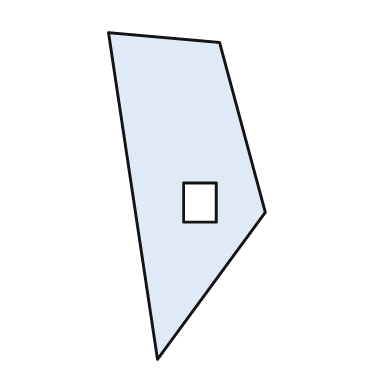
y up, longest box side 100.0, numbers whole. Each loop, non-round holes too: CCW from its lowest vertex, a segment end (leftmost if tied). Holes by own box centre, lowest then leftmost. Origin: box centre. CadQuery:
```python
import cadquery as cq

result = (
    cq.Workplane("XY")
    .moveTo(-9.0, -50.0)
    .lineTo(24.0, -5.0)
    .lineTo(10.0, 47.0)
    .lineTo(-24.0, 50.0)
    .close()
    .moveTo(-1.0, -8.0)
    .lineTo(9.0, -8.0)
    .lineTo(9.0, 4.0)
    .lineTo(-1.0, 4.0)
    .close()
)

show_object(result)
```